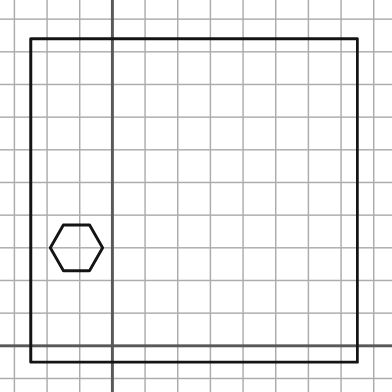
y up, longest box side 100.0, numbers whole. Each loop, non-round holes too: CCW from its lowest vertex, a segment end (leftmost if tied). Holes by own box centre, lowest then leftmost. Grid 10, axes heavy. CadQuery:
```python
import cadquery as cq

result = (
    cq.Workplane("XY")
    .moveTo(-25.0, -5.0)
    .lineTo(75.0, -5.0)
    .lineTo(75.0, 94.0)
    .lineTo(-25.0, 94.0)
    .close()
    .moveTo(-15.0, 23.0)
    .lineTo(-7.0, 23.0)
    .lineTo(-3.0, 30.0)
    .lineTo(-7.0, 37.0)
    .lineTo(-15.0, 37.0)
    .lineTo(-19.0, 30.0)
    .close()
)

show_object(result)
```